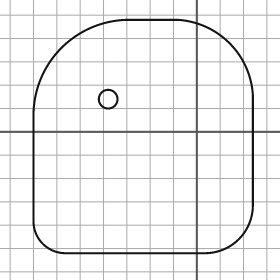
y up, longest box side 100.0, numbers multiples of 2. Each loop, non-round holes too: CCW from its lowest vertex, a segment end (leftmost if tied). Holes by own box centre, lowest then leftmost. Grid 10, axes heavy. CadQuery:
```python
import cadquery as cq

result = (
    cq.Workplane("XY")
    .moveTo(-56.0, -52.0)
    .lineTo(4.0, -52.0)
    .threePointArc((18.0, -46.0), (24.0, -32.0))
    .lineTo(24.0, 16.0)
    .threePointArc((14.0, 38.0), (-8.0, 48.0))
    .lineTo(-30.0, 48.0)
    .threePointArc((-58.0, 36.0), (-70.0, 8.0))
    .lineTo(-70.0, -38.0)
    .threePointArc((-66.0, -48.0), (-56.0, -52.0))
    .close()
    .moveTo(-38.0, 14.0)
    .circle(4.0)
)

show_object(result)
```